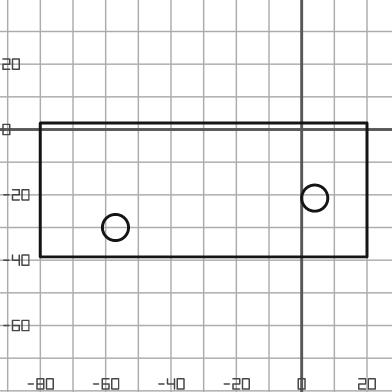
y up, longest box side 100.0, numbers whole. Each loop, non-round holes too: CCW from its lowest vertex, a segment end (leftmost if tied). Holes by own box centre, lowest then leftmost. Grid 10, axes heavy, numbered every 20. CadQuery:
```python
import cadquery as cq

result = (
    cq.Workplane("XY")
    .moveTo(-80.0, -39.0)
    .lineTo(20.0, -39.0)
    .lineTo(20.0, 2.0)
    .lineTo(-80.0, 2.0)
    .close()
    .moveTo(-57.0, -30.0)
    .circle(4.0)
    .moveTo(4.0, -21.0)
    .circle(4.0)
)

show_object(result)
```